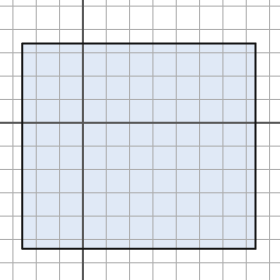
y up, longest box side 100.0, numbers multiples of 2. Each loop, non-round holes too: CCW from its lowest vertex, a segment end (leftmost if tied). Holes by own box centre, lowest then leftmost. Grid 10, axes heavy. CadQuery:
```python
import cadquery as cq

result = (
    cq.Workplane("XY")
    .moveTo(-26.0, -54.0)
    .lineTo(74.0, -54.0)
    .lineTo(74.0, 34.0)
    .lineTo(-26.0, 34.0)
    .close()
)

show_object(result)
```